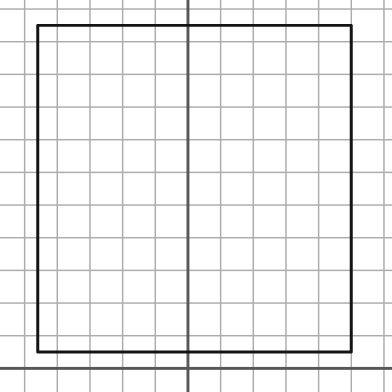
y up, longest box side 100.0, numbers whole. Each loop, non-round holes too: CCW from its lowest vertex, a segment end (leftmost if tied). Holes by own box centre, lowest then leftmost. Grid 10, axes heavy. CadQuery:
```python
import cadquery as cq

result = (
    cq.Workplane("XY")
    .moveTo(-46.0, 5.0)
    .lineTo(50.0, 5.0)
    .lineTo(50.0, 105.0)
    .lineTo(-46.0, 105.0)
    .close()
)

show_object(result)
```